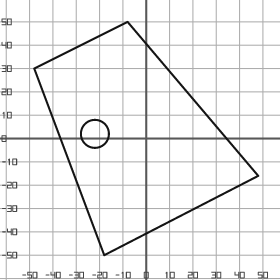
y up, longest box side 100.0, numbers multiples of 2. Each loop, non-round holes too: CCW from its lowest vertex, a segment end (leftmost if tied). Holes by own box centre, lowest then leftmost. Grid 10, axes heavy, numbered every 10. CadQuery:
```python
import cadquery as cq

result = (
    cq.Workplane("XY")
    .moveTo(-18.0, -50.0)
    .lineTo(48.0, -16.0)
    .lineTo(-8.0, 50.0)
    .lineTo(-48.0, 30.0)
    .close()
    .moveTo(-22.0, 2.0)
    .circle(6.0)
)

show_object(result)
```